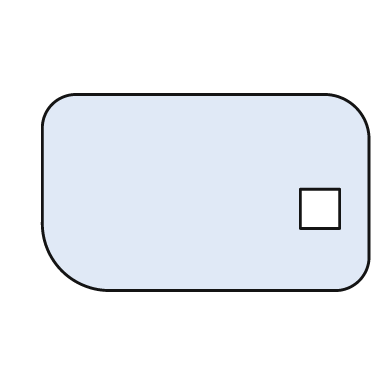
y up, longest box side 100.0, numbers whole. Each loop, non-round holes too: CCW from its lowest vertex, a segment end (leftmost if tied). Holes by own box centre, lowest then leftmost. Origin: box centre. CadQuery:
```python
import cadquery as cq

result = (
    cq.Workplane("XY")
    .moveTo(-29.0, -30.0)
    .lineTo(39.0, -30.0)
    .threePointArc((47.0, -27.0), (50.0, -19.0))
    .lineTo(50.0, 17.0)
    .threePointArc((46.0, 26.0), (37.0, 30.0))
    .lineTo(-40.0, 30.0)
    .threePointArc((-47.0, 27.0), (-50.0, 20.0))
    .lineTo(-50.0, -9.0)
    .threePointArc((-44.0, -24.0), (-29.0, -30.0))
    .close()
    .moveTo(29.0, -11.0)
    .lineTo(41.0, -11.0)
    .lineTo(41.0, 1.0)
    .lineTo(29.0, 1.0)
    .close()
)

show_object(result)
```